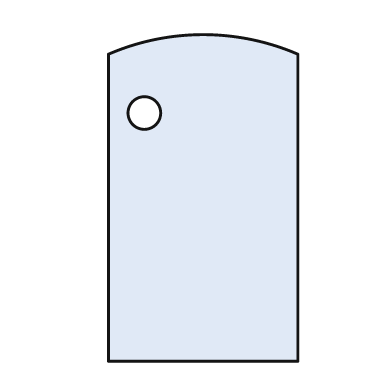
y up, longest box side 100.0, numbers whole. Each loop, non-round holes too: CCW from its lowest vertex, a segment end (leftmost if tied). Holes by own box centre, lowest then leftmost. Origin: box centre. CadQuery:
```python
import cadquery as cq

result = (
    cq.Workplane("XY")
    .moveTo(-29.0, -50.0)
    .lineTo(29.0, -50.0)
    .lineTo(29.0, 44.0)
    .threePointArc((0.0, 50.0), (-29.0, 44.0))
    .close()
    .moveTo(-18.0, 26.0)
    .circle(5.0)
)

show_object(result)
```